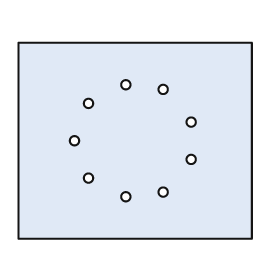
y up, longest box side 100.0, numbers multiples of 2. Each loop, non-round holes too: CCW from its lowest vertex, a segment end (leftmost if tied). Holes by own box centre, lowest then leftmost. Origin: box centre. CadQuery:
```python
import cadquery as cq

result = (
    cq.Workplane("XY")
    .moveTo(-50.0, -42.0)
    .lineTo(50.0, -42.0)
    .lineTo(50.0, 42.0)
    .lineTo(-50.0, 42.0)
    .close()
    .moveTo(-4.0, -24.0)
    .circle(2.0)
    .moveTo(12.0, -22.0)
    .circle(2.0)
    .moveTo(-20.0, -16.0)
    .circle(2.0)
    .moveTo(24.0, -8.0)
    .circle(2.0)
    .moveTo(-26.0, 0.0)
    .circle(2.0)
    .moveTo(24.0, 8.0)
    .circle(2.0)
    .moveTo(-20.0, 16.0)
    .circle(2.0)
    .moveTo(12.0, 22.0)
    .circle(2.0)
    .moveTo(-4.0, 24.0)
    .circle(2.0)
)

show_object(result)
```